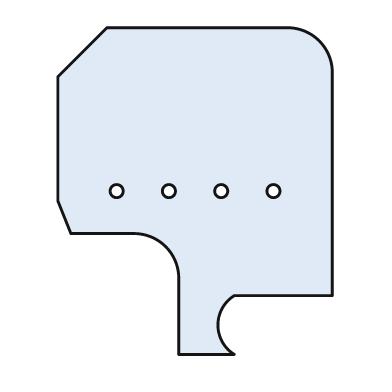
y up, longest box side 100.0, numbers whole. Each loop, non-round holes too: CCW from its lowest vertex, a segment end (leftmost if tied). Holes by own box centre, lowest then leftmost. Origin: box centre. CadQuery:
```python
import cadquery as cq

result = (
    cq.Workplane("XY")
    .moveTo(-5.0, -50.0)
    .lineTo(12.0, -50.0)
    .threePointArc((7.0, -41.0), (12.0, -32.0))
    .lineTo(42.0, -32.0)
    .lineTo(42.0, 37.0)
    .threePointArc((38.0, 46.0), (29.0, 50.0))
    .lineTo(-27.0, 50.0)
    .lineTo(-42.0, 35.0)
    .lineTo(-42.0, -3.0)
    .lineTo(-38.0, -13.0)
    .lineTo(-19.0, -13.0)
    .threePointArc((-9.0, -17.0), (-5.0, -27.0))
    .close()
    .moveTo(-24.0, 0.0)
    .circle(2.0)
    .moveTo(-8.0, 0.0)
    .circle(2.0)
    .moveTo(8.0, 0.0)
    .circle(2.0)
    .moveTo(24.0, 0.0)
    .circle(2.0)
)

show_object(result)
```